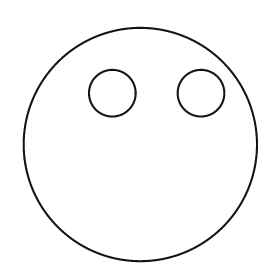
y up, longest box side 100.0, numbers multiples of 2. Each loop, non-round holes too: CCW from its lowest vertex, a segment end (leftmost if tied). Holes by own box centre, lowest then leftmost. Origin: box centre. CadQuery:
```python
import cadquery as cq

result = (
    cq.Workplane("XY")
    .moveTo(0.0, 0.0)
    .circle(50.0)
    .moveTo(-12.0, 22.0)
    .circle(10.0)
    .moveTo(26.0, 22.0)
    .circle(10.0)
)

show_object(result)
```